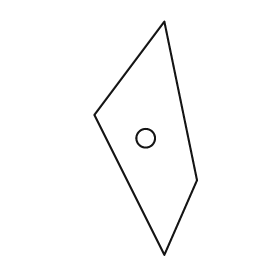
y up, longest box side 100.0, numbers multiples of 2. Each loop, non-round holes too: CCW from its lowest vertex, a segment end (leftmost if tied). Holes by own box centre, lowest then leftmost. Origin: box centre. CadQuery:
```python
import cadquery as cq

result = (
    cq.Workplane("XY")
    .moveTo(8.0, -50.0)
    .lineTo(22.0, -18.0)
    .lineTo(8.0, 50.0)
    .lineTo(-22.0, 10.0)
    .close()
    .moveTo(0.0, 0.0)
    .circle(4.0)
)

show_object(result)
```